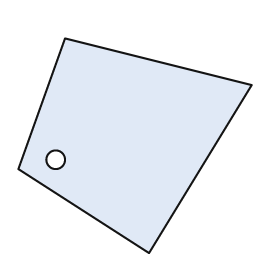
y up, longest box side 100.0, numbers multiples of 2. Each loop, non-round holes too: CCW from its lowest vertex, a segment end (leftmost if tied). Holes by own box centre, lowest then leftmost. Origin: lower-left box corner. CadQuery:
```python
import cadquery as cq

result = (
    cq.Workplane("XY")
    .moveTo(56.0, 0.0)
    .lineTo(100.0, 72.0)
    .lineTo(20.0, 92.0)
    .lineTo(0.0, 36.0)
    .close()
    .moveTo(16.0, 40.0)
    .circle(4.0)
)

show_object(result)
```